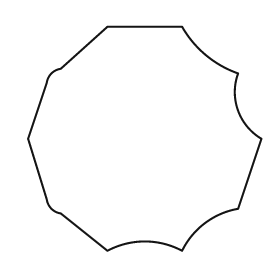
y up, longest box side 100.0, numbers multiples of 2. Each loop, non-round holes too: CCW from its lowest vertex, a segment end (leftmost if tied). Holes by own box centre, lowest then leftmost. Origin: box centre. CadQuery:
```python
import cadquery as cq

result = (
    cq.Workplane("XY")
    .moveTo(-16.0, -48.0)
    .threePointArc((0.0, -44.0), (16.0, -48.0))
    .threePointArc((26.0, -36.0), (40.0, -30.0))
    .lineTo(50.0, 0.0)
    .threePointArc((40.0, 12.0), (40.0, 28.0))
    .threePointArc((26.0, 36.0), (16.0, 48.0))
    .lineTo(-16.0, 48.0)
    .lineTo(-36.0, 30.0)
    .threePointArc((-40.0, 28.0), (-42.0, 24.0))
    .lineTo(-50.0, 0.0)
    .lineTo(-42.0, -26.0)
    .threePointArc((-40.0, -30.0), (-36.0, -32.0))
    .close()
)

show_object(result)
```